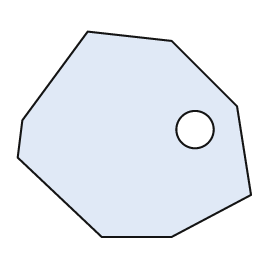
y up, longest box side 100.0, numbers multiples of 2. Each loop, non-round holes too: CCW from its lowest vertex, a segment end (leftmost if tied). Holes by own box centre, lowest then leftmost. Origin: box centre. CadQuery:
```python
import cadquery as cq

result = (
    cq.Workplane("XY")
    .moveTo(-14.0, -44.0)
    .lineTo(16.0, -44.0)
    .lineTo(50.0, -26.0)
    .lineTo(44.0, 12.0)
    .lineTo(16.0, 40.0)
    .lineTo(-20.0, 44.0)
    .lineTo(-48.0, 6.0)
    .lineTo(-50.0, -10.0)
    .close()
    .moveTo(26.0, 2.0)
    .circle(8.0)
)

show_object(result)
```